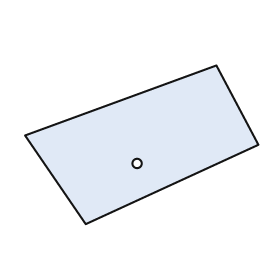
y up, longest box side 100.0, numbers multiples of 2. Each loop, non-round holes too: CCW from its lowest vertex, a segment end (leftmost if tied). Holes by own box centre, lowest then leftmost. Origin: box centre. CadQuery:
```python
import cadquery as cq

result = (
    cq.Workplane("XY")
    .moveTo(-24.0, -34.0)
    .lineTo(50.0, 0.0)
    .lineTo(32.0, 34.0)
    .lineTo(-50.0, 4.0)
    .close()
    .moveTo(-2.0, -8.0)
    .circle(2.0)
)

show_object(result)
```